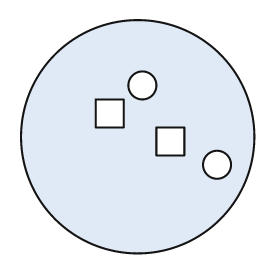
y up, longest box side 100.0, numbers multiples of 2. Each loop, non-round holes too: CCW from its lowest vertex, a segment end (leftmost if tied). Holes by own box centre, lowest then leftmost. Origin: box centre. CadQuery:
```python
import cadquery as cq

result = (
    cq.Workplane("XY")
    .moveTo(0.0, 0.0)
    .circle(50.0)
    .moveTo(34.0, -12.0)
    .circle(6.0)
    .moveTo(8.0, -8.0)
    .lineTo(20.0, -8.0)
    .lineTo(20.0, 4.0)
    .lineTo(8.0, 4.0)
    .close()
    .moveTo(-18.0, 4.0)
    .lineTo(-6.0, 4.0)
    .lineTo(-6.0, 16.0)
    .lineTo(-18.0, 16.0)
    .close()
    .moveTo(2.0, 22.0)
    .circle(6.0)
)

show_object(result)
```